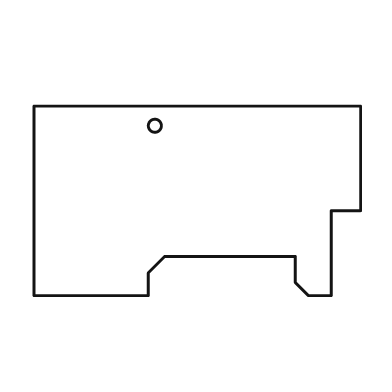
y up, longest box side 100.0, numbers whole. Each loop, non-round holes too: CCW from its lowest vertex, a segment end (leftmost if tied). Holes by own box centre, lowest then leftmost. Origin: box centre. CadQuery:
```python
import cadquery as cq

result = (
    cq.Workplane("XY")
    .moveTo(-50.0, -29.0)
    .lineTo(-15.0, -29.0)
    .lineTo(-15.0, -22.0)
    .lineTo(-10.0, -17.0)
    .lineTo(30.0, -17.0)
    .lineTo(30.0, -25.0)
    .lineTo(34.0, -29.0)
    .lineTo(41.0, -29.0)
    .lineTo(41.0, -3.0)
    .lineTo(50.0, -3.0)
    .lineTo(50.0, 29.0)
    .lineTo(-50.0, 29.0)
    .close()
    .moveTo(-13.0, 23.0)
    .circle(2.0)
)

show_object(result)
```